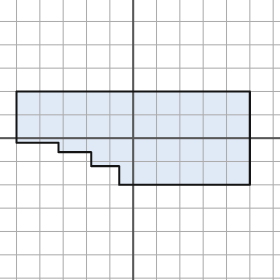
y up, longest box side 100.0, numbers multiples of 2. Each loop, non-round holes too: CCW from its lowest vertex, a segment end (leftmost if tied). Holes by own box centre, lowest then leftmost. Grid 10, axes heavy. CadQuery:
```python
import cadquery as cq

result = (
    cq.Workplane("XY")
    .moveTo(-6.0, -20.0)
    .lineTo(50.0, -20.0)
    .lineTo(50.0, 20.0)
    .lineTo(-50.0, 20.0)
    .lineTo(-50.0, -2.0)
    .lineTo(-32.0, -2.0)
    .lineTo(-32.0, -6.0)
    .lineTo(-18.0, -6.0)
    .lineTo(-18.0, -12.0)
    .lineTo(-6.0, -12.0)
    .close()
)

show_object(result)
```